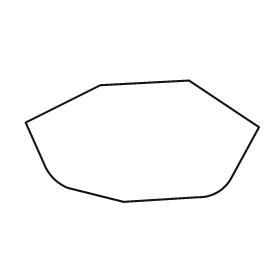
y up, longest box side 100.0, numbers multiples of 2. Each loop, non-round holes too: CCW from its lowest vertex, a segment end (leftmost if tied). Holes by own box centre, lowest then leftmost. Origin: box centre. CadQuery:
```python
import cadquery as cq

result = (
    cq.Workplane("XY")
    .moveTo(-8.0, -26.0)
    .lineTo(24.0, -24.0)
    .threePointArc((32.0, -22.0), (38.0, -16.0))
    .lineTo(50.0, 6.0)
    .lineTo(20.0, 26.0)
    .lineTo(-18.0, 24.0)
    .lineTo(-50.0, 8.0)
    .lineTo(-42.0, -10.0)
    .threePointArc((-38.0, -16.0), (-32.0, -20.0))
    .close()
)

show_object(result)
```